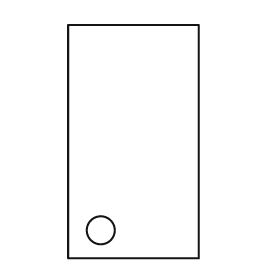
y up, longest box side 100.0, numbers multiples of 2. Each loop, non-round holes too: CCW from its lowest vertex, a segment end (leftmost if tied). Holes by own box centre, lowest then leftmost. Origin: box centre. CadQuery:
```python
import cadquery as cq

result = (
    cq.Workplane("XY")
    .moveTo(-28.0, -50.0)
    .lineTo(28.0, -50.0)
    .lineTo(28.0, 50.0)
    .lineTo(-28.0, 50.0)
    .close()
    .moveTo(-14.0, -38.0)
    .circle(6.0)
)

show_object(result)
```